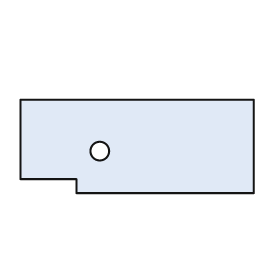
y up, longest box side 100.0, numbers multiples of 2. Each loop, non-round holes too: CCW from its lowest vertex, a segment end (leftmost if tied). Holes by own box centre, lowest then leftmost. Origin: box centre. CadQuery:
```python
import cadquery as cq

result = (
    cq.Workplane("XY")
    .moveTo(-26.0, -20.0)
    .lineTo(50.0, -20.0)
    .lineTo(50.0, 20.0)
    .lineTo(-50.0, 20.0)
    .lineTo(-50.0, -14.0)
    .lineTo(-26.0, -14.0)
    .close()
    .moveTo(-16.0, -2.0)
    .circle(4.0)
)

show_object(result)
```